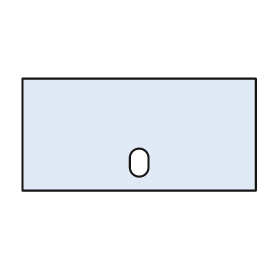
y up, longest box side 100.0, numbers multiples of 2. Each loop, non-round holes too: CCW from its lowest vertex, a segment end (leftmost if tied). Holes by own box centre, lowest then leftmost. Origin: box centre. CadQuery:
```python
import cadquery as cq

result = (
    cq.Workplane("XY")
    .moveTo(-50.0, -24.0)
    .lineTo(50.0, -24.0)
    .lineTo(50.0, 24.0)
    .lineTo(-50.0, 24.0)
    .close()
    .moveTo(-4.0, -14.0)
    .threePointArc((0.0, -18.0), (4.0, -14.0))
    .lineTo(4.0, -10.0)
    .threePointArc((0.0, -6.0), (-4.0, -10.0))
    .close()
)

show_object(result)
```